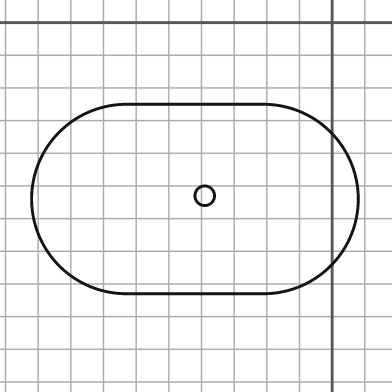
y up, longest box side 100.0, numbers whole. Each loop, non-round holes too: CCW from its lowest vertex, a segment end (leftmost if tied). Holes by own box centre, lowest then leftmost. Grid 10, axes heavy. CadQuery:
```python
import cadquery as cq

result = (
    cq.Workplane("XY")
    .moveTo(-63.0, -83.0)
    .lineTo(-21.0, -83.0)
    .threePointArc((8.0, -54.0), (-21.0, -25.0))
    .lineTo(-63.0, -25.0)
    .threePointArc((-92.0, -54.0), (-63.0, -83.0))
    .close()
    .moveTo(-39.0, -53.0)
    .circle(3.0)
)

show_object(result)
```